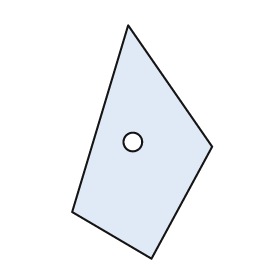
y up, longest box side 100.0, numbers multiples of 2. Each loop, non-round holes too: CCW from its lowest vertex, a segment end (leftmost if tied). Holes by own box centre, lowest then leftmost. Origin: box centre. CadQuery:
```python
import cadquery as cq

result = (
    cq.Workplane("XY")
    .moveTo(4.0, -50.0)
    .lineTo(30.0, -2.0)
    .lineTo(-6.0, 50.0)
    .lineTo(-30.0, -30.0)
    .close()
    .moveTo(-4.0, 0.0)
    .circle(4.0)
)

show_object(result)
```